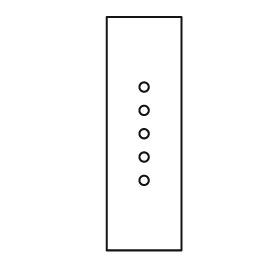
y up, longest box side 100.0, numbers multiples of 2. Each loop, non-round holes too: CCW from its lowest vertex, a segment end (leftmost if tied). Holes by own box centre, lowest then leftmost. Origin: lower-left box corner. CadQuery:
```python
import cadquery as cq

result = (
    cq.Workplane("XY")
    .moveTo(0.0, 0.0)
    .lineTo(32.0, 0.0)
    .lineTo(32.0, 100.0)
    .lineTo(0.0, 100.0)
    .close()
    .moveTo(16.0, 30.0)
    .circle(2.0)
    .moveTo(16.0, 40.0)
    .circle(2.0)
    .moveTo(16.0, 50.0)
    .circle(2.0)
    .moveTo(16.0, 60.0)
    .circle(2.0)
    .moveTo(16.0, 70.0)
    .circle(2.0)
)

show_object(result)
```